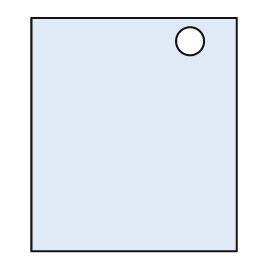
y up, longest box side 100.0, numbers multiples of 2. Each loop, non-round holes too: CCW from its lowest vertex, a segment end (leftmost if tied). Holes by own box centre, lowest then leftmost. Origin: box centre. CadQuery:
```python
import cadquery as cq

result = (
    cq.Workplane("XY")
    .moveTo(-44.0, -50.0)
    .lineTo(44.0, -50.0)
    .lineTo(44.0, 50.0)
    .lineTo(-44.0, 50.0)
    .close()
    .moveTo(24.0, 40.0)
    .circle(6.0)
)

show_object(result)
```